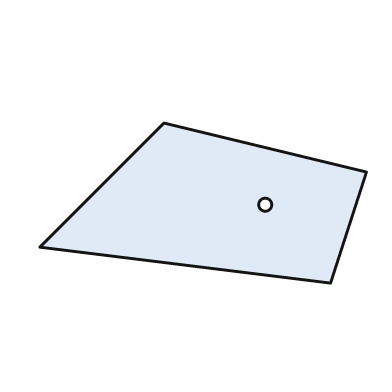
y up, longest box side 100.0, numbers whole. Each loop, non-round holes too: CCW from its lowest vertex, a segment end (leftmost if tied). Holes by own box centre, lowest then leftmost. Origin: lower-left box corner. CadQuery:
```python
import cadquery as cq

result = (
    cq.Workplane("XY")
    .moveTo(89.0, 0.0)
    .lineTo(100.0, 34.0)
    .lineTo(38.0, 49.0)
    .lineTo(0.0, 11.0)
    .close()
    .moveTo(69.0, 24.0)
    .circle(2.0)
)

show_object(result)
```